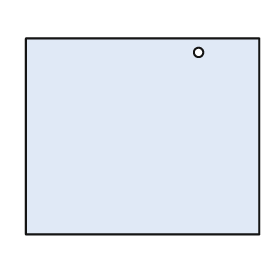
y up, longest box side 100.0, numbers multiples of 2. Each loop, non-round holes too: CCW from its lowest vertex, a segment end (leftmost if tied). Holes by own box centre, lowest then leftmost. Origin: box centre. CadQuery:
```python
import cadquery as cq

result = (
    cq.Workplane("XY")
    .moveTo(-50.0, -42.0)
    .lineTo(50.0, -42.0)
    .lineTo(50.0, 42.0)
    .lineTo(-50.0, 42.0)
    .close()
    .moveTo(24.0, 36.0)
    .circle(2.0)
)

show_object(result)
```